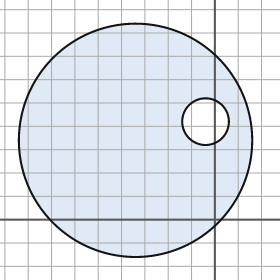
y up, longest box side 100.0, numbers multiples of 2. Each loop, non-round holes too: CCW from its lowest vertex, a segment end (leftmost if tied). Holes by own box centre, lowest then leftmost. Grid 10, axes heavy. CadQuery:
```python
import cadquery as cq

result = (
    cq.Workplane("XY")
    .moveTo(-34.0, 34.0)
    .circle(50.0)
    .moveTo(-4.0, 42.0)
    .circle(10.0)
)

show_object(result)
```